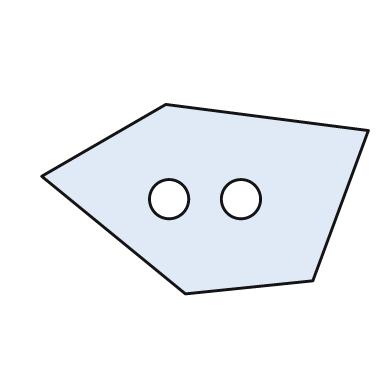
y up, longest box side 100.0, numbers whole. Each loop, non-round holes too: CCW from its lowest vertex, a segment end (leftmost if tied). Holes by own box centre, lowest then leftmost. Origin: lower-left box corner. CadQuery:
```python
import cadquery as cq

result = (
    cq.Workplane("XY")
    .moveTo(44.0, 0.0)
    .lineTo(83.0, 4.0)
    .lineTo(100.0, 50.0)
    .lineTo(38.0, 58.0)
    .lineTo(0.0, 36.0)
    .close()
    .moveTo(39.0, 29.0)
    .circle(6.0)
    .moveTo(61.0, 29.0)
    .circle(6.0)
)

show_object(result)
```